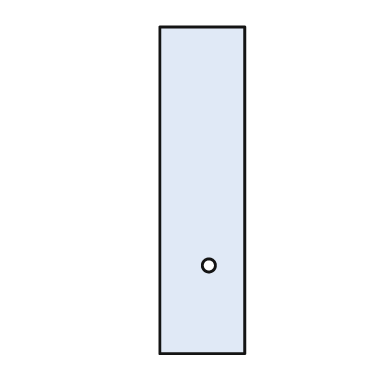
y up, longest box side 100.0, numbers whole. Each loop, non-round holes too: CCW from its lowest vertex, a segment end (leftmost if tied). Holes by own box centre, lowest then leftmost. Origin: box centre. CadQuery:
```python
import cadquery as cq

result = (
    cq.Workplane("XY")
    .moveTo(-13.0, -50.0)
    .lineTo(13.0, -50.0)
    .lineTo(13.0, 50.0)
    .lineTo(-13.0, 50.0)
    .close()
    .moveTo(2.0, -23.0)
    .circle(2.0)
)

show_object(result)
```